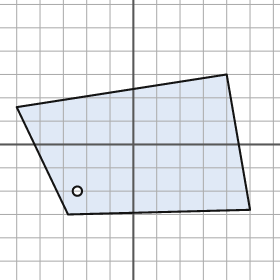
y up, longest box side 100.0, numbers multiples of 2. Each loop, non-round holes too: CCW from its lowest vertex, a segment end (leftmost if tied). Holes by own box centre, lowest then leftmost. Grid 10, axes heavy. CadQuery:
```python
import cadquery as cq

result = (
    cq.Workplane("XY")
    .moveTo(-28.0, -30.0)
    .lineTo(50.0, -28.0)
    .lineTo(40.0, 30.0)
    .lineTo(-50.0, 16.0)
    .close()
    .moveTo(-24.0, -20.0)
    .circle(2.0)
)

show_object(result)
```